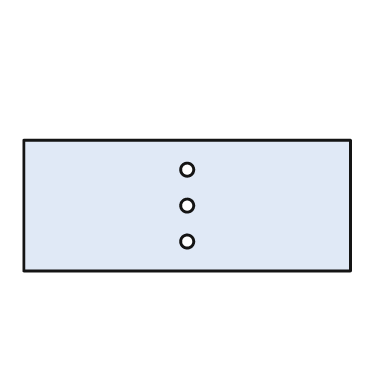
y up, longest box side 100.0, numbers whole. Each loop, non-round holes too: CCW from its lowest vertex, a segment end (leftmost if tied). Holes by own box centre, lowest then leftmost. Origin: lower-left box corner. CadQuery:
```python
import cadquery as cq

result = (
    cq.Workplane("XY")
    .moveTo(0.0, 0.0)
    .lineTo(100.0, 0.0)
    .lineTo(100.0, 40.0)
    .lineTo(0.0, 40.0)
    .close()
    .moveTo(50.0, 9.0)
    .circle(2.0)
    .moveTo(50.0, 20.0)
    .circle(2.0)
    .moveTo(50.0, 31.0)
    .circle(2.0)
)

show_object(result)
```